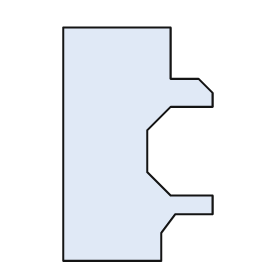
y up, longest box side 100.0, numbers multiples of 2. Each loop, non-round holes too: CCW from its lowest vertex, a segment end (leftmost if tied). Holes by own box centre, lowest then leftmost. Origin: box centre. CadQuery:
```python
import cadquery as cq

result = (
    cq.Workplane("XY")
    .moveTo(-32.0, -50.0)
    .lineTo(10.0, -50.0)
    .lineTo(10.0, -38.0)
    .lineTo(16.0, -30.0)
    .lineTo(32.0, -30.0)
    .lineTo(32.0, -22.0)
    .lineTo(14.0, -22.0)
    .lineTo(4.0, -12.0)
    .lineTo(4.0, 6.0)
    .lineTo(14.0, 16.0)
    .lineTo(32.0, 16.0)
    .lineTo(32.0, 22.0)
    .lineTo(26.0, 28.0)
    .lineTo(14.0, 28.0)
    .lineTo(14.0, 50.0)
    .lineTo(-32.0, 50.0)
    .close()
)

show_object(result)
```